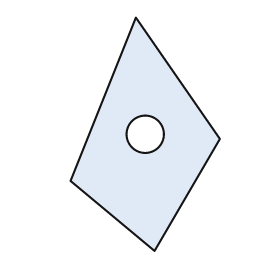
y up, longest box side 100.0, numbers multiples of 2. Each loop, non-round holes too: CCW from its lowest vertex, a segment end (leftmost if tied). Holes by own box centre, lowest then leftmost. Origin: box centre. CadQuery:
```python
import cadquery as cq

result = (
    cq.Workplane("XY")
    .moveTo(4.0, -50.0)
    .lineTo(32.0, -2.0)
    .lineTo(-4.0, 50.0)
    .lineTo(-32.0, -20.0)
    .close()
    .moveTo(0.0, 0.0)
    .circle(8.0)
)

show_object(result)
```